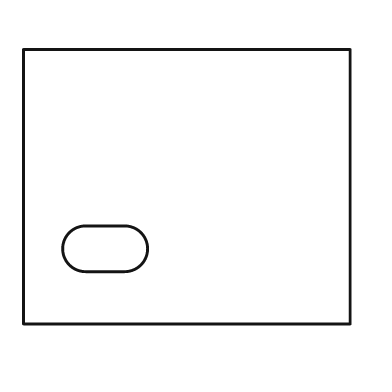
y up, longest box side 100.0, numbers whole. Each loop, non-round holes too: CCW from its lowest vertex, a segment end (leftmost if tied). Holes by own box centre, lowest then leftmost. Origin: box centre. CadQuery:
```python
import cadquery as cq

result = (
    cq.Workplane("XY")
    .moveTo(-50.0, -42.0)
    .lineTo(50.0, -42.0)
    .lineTo(50.0, 42.0)
    .lineTo(-50.0, 42.0)
    .close()
    .moveTo(-31.0, -26.0)
    .lineTo(-19.0, -26.0)
    .threePointArc((-12.0, -19.0), (-19.0, -12.0))
    .lineTo(-31.0, -12.0)
    .threePointArc((-38.0, -19.0), (-31.0, -26.0))
    .close()
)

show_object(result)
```